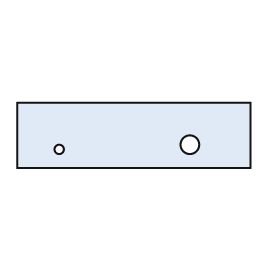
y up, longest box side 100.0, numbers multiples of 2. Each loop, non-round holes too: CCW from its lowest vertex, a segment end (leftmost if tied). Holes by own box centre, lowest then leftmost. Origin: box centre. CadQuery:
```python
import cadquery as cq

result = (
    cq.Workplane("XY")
    .moveTo(-50.0, -14.0)
    .lineTo(50.0, -14.0)
    .lineTo(50.0, 14.0)
    .lineTo(-50.0, 14.0)
    .close()
    .moveTo(-32.0, -6.0)
    .circle(2.0)
    .moveTo(24.0, -4.0)
    .circle(4.0)
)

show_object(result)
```